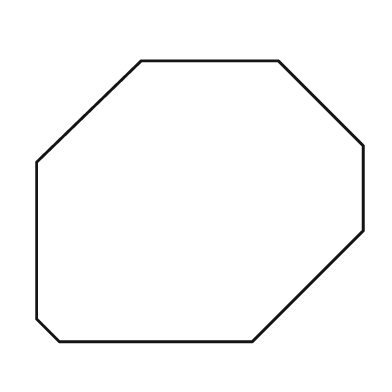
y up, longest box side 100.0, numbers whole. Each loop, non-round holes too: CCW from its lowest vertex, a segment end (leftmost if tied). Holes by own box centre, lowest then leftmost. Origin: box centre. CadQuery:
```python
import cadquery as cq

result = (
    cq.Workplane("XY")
    .moveTo(-43.0, -43.0)
    .lineTo(16.0, -43.0)
    .lineTo(50.0, -9.0)
    .lineTo(50.0, 17.0)
    .lineTo(24.0, 43.0)
    .lineTo(-18.0, 43.0)
    .lineTo(-50.0, 12.0)
    .lineTo(-50.0, -36.0)
    .close()
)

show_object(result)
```